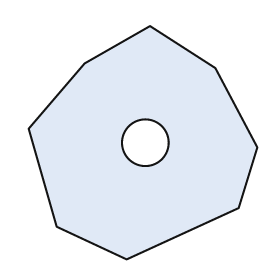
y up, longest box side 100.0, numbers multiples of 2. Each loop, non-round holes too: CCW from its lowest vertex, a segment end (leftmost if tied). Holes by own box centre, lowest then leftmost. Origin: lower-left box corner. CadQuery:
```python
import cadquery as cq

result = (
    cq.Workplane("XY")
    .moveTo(42.0, 0.0)
    .lineTo(90.0, 22.0)
    .lineTo(98.0, 48.0)
    .lineTo(80.0, 82.0)
    .lineTo(52.0, 100.0)
    .lineTo(24.0, 84.0)
    .lineTo(0.0, 56.0)
    .lineTo(12.0, 14.0)
    .close()
    .moveTo(50.0, 50.0)
    .circle(10.0)
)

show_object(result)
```